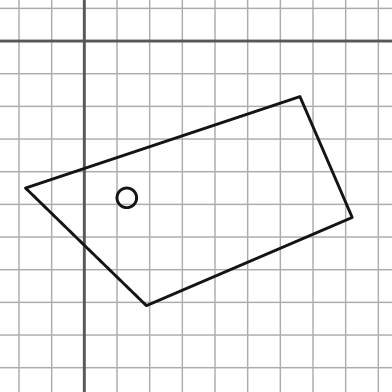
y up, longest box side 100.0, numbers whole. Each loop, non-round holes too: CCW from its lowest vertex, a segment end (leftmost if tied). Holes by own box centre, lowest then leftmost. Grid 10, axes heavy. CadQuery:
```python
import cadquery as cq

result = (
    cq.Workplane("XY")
    .moveTo(19.0, -81.0)
    .lineTo(82.0, -54.0)
    .lineTo(66.0, -17.0)
    .lineTo(-18.0, -45.0)
    .close()
    .moveTo(13.0, -48.0)
    .circle(3.0)
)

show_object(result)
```